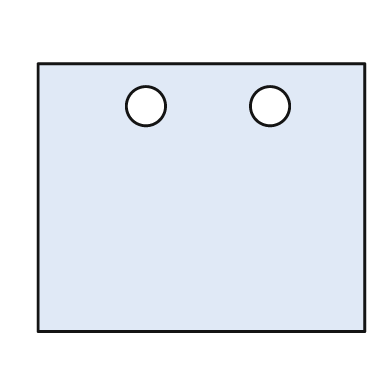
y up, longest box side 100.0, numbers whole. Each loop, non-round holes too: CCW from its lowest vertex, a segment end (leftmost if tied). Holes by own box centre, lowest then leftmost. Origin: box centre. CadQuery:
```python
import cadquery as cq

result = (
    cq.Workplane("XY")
    .moveTo(-50.0, -41.0)
    .lineTo(50.0, -41.0)
    .lineTo(50.0, 41.0)
    .lineTo(-50.0, 41.0)
    .close()
    .moveTo(-17.0, 28.0)
    .circle(6.0)
    .moveTo(21.0, 28.0)
    .circle(6.0)
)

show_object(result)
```